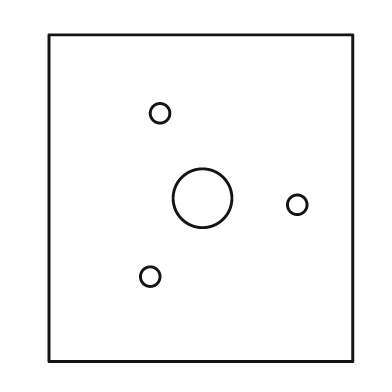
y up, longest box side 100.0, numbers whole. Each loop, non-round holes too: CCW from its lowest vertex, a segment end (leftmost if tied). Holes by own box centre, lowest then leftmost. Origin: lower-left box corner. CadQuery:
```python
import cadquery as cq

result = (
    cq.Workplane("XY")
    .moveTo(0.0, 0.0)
    .lineTo(93.0, 0.0)
    .lineTo(93.0, 100.0)
    .lineTo(0.0, 100.0)
    .close()
    .moveTo(31.0, 26.0)
    .circle(3.0)
    .moveTo(76.0, 48.0)
    .circle(3.0)
    .moveTo(47.0, 50.0)
    .circle(9.0)
    .moveTo(34.0, 76.0)
    .circle(3.0)
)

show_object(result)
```